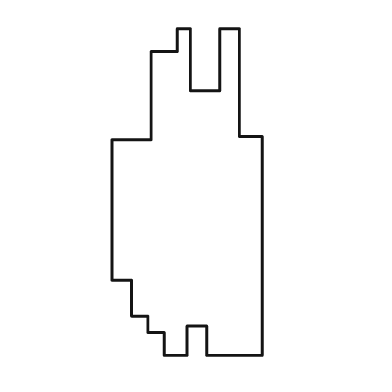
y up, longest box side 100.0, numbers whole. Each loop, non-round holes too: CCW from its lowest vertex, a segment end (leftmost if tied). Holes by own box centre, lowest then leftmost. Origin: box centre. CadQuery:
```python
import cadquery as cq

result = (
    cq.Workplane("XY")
    .moveTo(-7.0, -50.0)
    .lineTo(0.0, -50.0)
    .lineTo(0.0, -41.0)
    .lineTo(6.0, -41.0)
    .lineTo(6.0, -50.0)
    .lineTo(23.0, -50.0)
    .lineTo(23.0, 17.0)
    .lineTo(16.0, 17.0)
    .lineTo(16.0, 50.0)
    .lineTo(10.0, 50.0)
    .lineTo(10.0, 31.0)
    .lineTo(1.0, 31.0)
    .lineTo(1.0, 50.0)
    .lineTo(-3.0, 50.0)
    .lineTo(-3.0, 43.0)
    .lineTo(-11.0, 43.0)
    .lineTo(-11.0, 16.0)
    .lineTo(-23.0, 16.0)
    .lineTo(-23.0, -27.0)
    .lineTo(-17.0, -27.0)
    .lineTo(-17.0, -38.0)
    .lineTo(-12.0, -38.0)
    .lineTo(-12.0, -43.0)
    .lineTo(-7.0, -43.0)
    .close()
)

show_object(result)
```